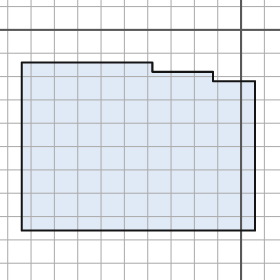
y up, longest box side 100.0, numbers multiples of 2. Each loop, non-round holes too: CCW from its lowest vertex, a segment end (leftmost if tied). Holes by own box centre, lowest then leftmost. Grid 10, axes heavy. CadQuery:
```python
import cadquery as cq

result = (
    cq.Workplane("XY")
    .moveTo(-94.0, -86.0)
    .lineTo(6.0, -86.0)
    .lineTo(6.0, -22.0)
    .lineTo(-12.0, -22.0)
    .lineTo(-12.0, -18.0)
    .lineTo(-38.0, -18.0)
    .lineTo(-38.0, -14.0)
    .lineTo(-94.0, -14.0)
    .close()
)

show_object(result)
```